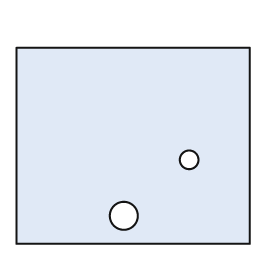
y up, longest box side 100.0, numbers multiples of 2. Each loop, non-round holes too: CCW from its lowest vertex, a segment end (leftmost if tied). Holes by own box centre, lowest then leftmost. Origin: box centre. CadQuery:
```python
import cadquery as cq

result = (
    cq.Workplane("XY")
    .moveTo(-50.0, -42.0)
    .lineTo(50.0, -42.0)
    .lineTo(50.0, 42.0)
    .lineTo(-50.0, 42.0)
    .close()
    .moveTo(-4.0, -30.0)
    .circle(6.0)
    .moveTo(24.0, -6.0)
    .circle(4.0)
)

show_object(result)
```